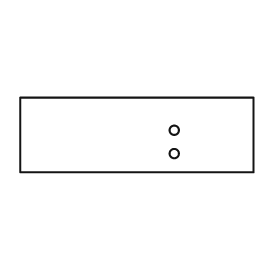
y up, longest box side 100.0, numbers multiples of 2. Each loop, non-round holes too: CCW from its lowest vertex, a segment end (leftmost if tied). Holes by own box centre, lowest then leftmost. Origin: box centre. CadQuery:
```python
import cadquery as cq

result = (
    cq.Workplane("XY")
    .moveTo(-50.0, -16.0)
    .lineTo(50.0, -16.0)
    .lineTo(50.0, 16.0)
    .lineTo(-50.0, 16.0)
    .close()
    .moveTo(16.0, -8.0)
    .circle(2.0)
    .moveTo(16.0, 2.0)
    .circle(2.0)
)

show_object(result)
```